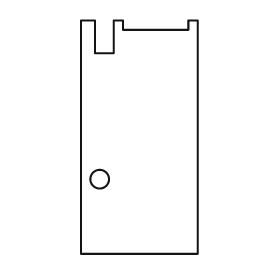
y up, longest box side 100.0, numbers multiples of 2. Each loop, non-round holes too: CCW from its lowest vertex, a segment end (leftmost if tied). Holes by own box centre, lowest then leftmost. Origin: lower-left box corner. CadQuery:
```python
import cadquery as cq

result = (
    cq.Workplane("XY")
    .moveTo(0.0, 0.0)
    .lineTo(50.0, 0.0)
    .lineTo(50.0, 100.0)
    .lineTo(46.0, 100.0)
    .lineTo(46.0, 96.0)
    .lineTo(18.0, 96.0)
    .lineTo(18.0, 100.0)
    .lineTo(14.0, 100.0)
    .lineTo(14.0, 86.0)
    .lineTo(6.0, 86.0)
    .lineTo(6.0, 100.0)
    .lineTo(0.0, 100.0)
    .close()
    .moveTo(8.0, 32.0)
    .circle(4.0)
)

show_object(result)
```